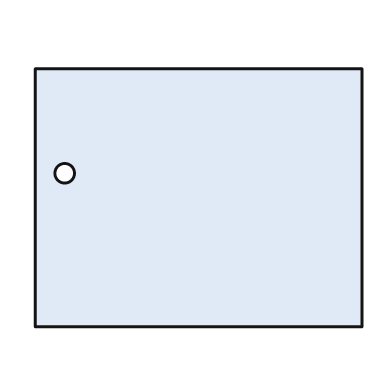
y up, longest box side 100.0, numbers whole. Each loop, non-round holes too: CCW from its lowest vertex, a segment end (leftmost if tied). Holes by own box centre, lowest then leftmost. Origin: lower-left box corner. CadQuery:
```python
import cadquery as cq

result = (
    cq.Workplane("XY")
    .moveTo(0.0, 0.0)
    .lineTo(100.0, 0.0)
    .lineTo(100.0, 79.0)
    .lineTo(0.0, 79.0)
    .close()
    .moveTo(9.0, 47.0)
    .circle(3.0)
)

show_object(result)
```